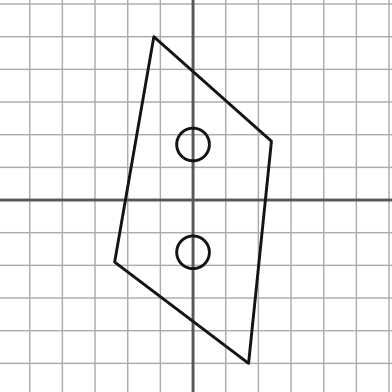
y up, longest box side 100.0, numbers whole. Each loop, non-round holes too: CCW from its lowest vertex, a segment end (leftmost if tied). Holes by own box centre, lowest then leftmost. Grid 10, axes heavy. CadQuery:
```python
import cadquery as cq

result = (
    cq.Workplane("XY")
    .moveTo(17.0, -50.0)
    .lineTo(24.0, 18.0)
    .lineTo(-12.0, 50.0)
    .lineTo(-24.0, -19.0)
    .close()
    .moveTo(0.0, -16.0)
    .circle(5.0)
    .moveTo(0.0, 17.0)
    .circle(5.0)
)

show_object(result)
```